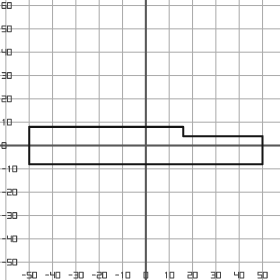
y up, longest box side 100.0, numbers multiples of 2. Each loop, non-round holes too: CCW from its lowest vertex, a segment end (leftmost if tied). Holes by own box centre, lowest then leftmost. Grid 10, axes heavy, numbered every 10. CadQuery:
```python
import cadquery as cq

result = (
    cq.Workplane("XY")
    .moveTo(-50.0, -8.0)
    .lineTo(50.0, -8.0)
    .lineTo(50.0, 4.0)
    .lineTo(16.0, 4.0)
    .lineTo(16.0, 8.0)
    .lineTo(-50.0, 8.0)
    .close()
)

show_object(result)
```